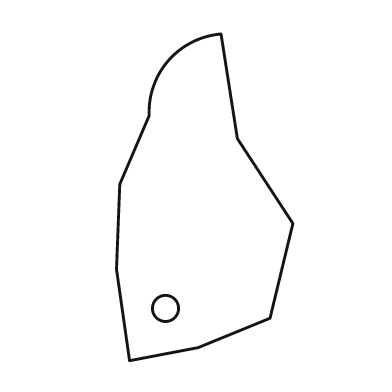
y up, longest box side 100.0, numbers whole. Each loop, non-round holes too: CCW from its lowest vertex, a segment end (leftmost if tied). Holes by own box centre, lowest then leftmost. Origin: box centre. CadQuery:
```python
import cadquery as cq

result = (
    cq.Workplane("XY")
    .moveTo(-23.0, -50.0)
    .lineTo(-2.0, -46.0)
    .lineTo(20.0, -37.0)
    .lineTo(27.0, -8.0)
    .lineTo(10.0, 18.0)
    .lineTo(5.0, 50.0)
    .threePointArc((-11.0, 42.0), (-17.0, 25.0))
    .lineTo(-26.0, 4.0)
    .lineTo(-27.0, -22.0)
    .close()
    .moveTo(-12.0, -34.0)
    .circle(4.0)
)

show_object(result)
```